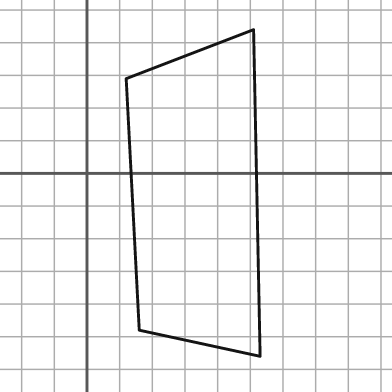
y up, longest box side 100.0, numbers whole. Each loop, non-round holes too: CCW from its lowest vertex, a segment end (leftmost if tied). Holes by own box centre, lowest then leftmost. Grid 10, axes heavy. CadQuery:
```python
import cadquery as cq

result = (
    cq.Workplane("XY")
    .moveTo(53.0, -56.0)
    .lineTo(51.0, 44.0)
    .lineTo(12.0, 29.0)
    .lineTo(16.0, -48.0)
    .close()
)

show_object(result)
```